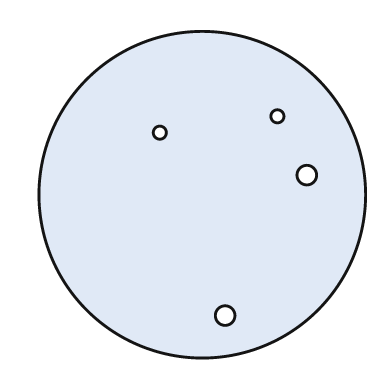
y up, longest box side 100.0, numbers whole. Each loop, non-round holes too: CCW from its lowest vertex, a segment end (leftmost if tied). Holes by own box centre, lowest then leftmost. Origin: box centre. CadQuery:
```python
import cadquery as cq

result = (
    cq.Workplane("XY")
    .moveTo(0.0, 0.0)
    .circle(50.0)
    .moveTo(7.0, -37.0)
    .circle(3.0)
    .moveTo(32.0, 6.0)
    .circle(3.0)
    .moveTo(-13.0, 19.0)
    .circle(2.0)
    .moveTo(23.0, 24.0)
    .circle(2.0)
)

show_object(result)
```